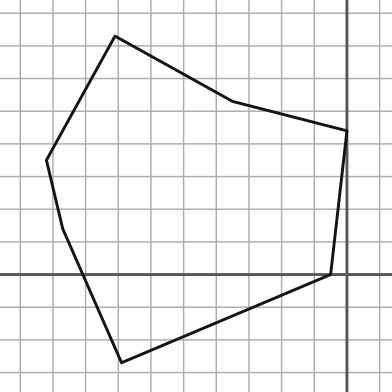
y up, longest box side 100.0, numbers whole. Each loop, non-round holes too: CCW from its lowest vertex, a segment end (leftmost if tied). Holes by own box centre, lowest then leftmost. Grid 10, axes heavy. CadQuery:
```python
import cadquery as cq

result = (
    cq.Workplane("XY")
    .moveTo(-69.0, -27.0)
    .lineTo(-5.0, 0.0)
    .lineTo(0.0, 44.0)
    .lineTo(-35.0, 53.0)
    .lineTo(-71.0, 73.0)
    .lineTo(-92.0, 35.0)
    .lineTo(-87.0, 14.0)
    .close()
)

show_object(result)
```